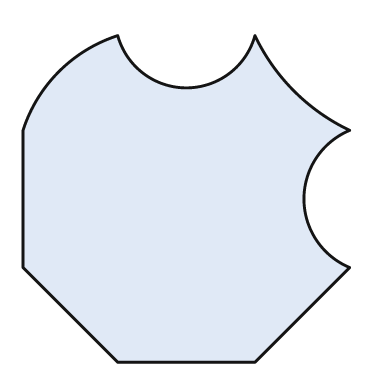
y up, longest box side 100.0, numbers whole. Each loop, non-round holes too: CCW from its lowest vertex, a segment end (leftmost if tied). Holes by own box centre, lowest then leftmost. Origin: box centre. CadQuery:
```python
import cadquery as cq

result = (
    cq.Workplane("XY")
    .moveTo(-21.0, -50.0)
    .lineTo(21.0, -50.0)
    .lineTo(50.0, -21.0)
    .threePointArc((36.0, 0.0), (50.0, 21.0))
    .threePointArc((33.0, 33.0), (21.0, 50.0))
    .threePointArc((0.0, 34.0), (-21.0, 50.0))
    .threePointArc((-39.0, 39.0), (-50.0, 21.0))
    .lineTo(-50.0, -21.0)
    .close()
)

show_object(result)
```